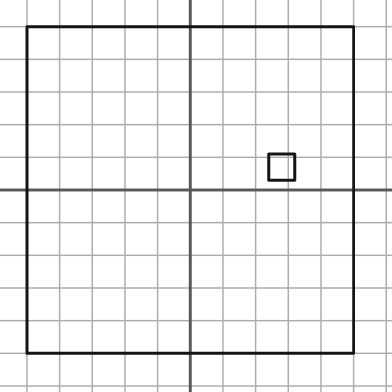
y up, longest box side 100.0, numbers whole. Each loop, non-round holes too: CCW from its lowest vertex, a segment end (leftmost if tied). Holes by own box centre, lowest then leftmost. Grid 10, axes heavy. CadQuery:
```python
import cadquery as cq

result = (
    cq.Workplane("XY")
    .moveTo(-50.0, -50.0)
    .lineTo(50.0, -50.0)
    .lineTo(50.0, 50.0)
    .lineTo(-50.0, 50.0)
    .close()
    .moveTo(24.0, 3.0)
    .lineTo(32.0, 3.0)
    .lineTo(32.0, 11.0)
    .lineTo(24.0, 11.0)
    .close()
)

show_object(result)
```